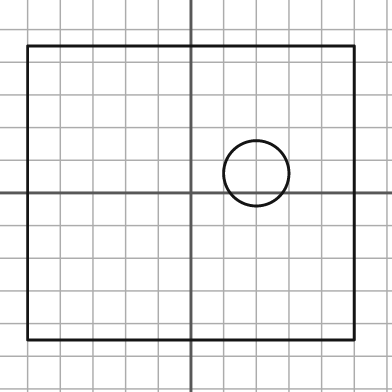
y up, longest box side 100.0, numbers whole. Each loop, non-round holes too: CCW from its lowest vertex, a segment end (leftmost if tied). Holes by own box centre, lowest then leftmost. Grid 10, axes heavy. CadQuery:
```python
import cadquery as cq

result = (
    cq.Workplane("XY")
    .moveTo(-50.0, -45.0)
    .lineTo(50.0, -45.0)
    .lineTo(50.0, 45.0)
    .lineTo(-50.0, 45.0)
    .close()
    .moveTo(20.0, 6.0)
    .circle(10.0)
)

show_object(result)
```